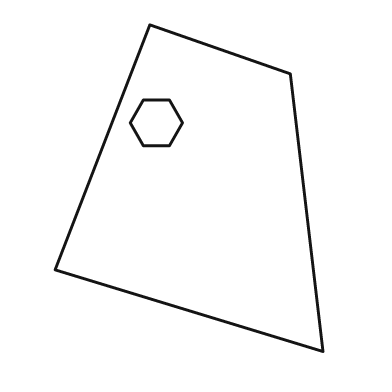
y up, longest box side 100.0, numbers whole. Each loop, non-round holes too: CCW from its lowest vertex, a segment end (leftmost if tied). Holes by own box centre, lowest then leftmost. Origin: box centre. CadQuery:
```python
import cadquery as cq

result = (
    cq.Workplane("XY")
    .moveTo(41.0, -50.0)
    .lineTo(31.0, 35.0)
    .lineTo(-12.0, 50.0)
    .lineTo(-41.0, -25.0)
    .close()
    .moveTo(-14.0, 13.0)
    .lineTo(-6.0, 13.0)
    .lineTo(-2.0, 20.0)
    .lineTo(-6.0, 27.0)
    .lineTo(-14.0, 27.0)
    .lineTo(-18.0, 20.0)
    .close()
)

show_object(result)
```